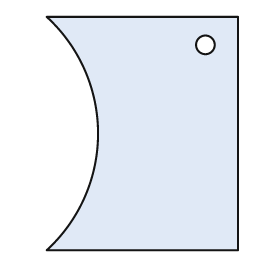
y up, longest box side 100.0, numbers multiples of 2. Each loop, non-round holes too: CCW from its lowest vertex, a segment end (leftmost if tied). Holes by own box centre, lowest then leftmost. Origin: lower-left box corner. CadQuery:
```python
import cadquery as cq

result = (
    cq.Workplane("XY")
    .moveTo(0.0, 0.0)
    .lineTo(82.0, 0.0)
    .lineTo(82.0, 100.0)
    .lineTo(0.0, 100.0)
    .threePointArc((22.0, 50.0), (0.0, 0.0))
    .close()
    .moveTo(68.0, 88.0)
    .circle(4.0)
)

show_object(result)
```